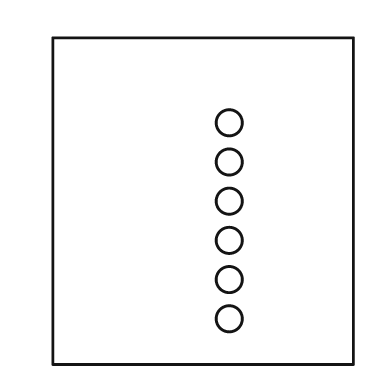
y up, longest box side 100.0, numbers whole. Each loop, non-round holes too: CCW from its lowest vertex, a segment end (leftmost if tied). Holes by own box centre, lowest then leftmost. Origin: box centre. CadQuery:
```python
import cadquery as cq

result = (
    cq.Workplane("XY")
    .moveTo(-46.0, -50.0)
    .lineTo(46.0, -50.0)
    .lineTo(46.0, 50.0)
    .lineTo(-46.0, 50.0)
    .close()
    .moveTo(8.0, -36.0)
    .circle(4.0)
    .moveTo(8.0, -24.0)
    .circle(4.0)
    .moveTo(8.0, -12.0)
    .circle(4.0)
    .moveTo(8.0, 0.0)
    .circle(4.0)
    .moveTo(8.0, 12.0)
    .circle(4.0)
    .moveTo(8.0, 24.0)
    .circle(4.0)
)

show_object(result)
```